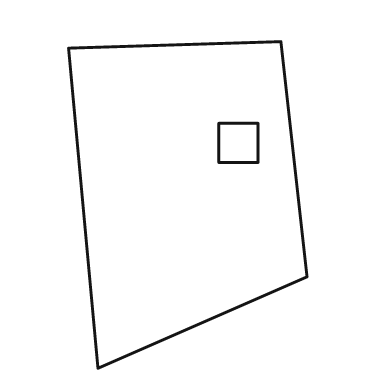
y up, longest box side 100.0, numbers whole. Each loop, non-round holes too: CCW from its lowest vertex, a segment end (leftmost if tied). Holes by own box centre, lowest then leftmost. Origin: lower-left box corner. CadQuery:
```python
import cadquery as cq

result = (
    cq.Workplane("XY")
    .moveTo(9.0, 0.0)
    .lineTo(73.0, 28.0)
    .lineTo(65.0, 100.0)
    .lineTo(0.0, 98.0)
    .close()
    .moveTo(46.0, 63.0)
    .lineTo(58.0, 63.0)
    .lineTo(58.0, 75.0)
    .lineTo(46.0, 75.0)
    .close()
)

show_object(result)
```